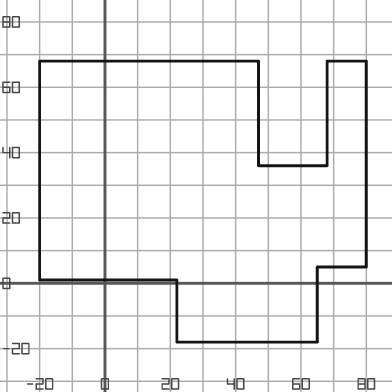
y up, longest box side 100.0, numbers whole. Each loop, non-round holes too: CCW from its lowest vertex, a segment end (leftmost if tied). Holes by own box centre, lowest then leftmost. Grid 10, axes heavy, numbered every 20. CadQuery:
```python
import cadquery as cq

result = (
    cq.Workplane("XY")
    .moveTo(22.0, -18.0)
    .lineTo(65.0, -18.0)
    .lineTo(65.0, 5.0)
    .lineTo(80.0, 5.0)
    .lineTo(80.0, 68.0)
    .lineTo(68.0, 68.0)
    .lineTo(68.0, 36.0)
    .lineTo(47.0, 36.0)
    .lineTo(47.0, 68.0)
    .lineTo(-20.0, 68.0)
    .lineTo(-20.0, 1.0)
    .lineTo(22.0, 1.0)
    .close()
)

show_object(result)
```